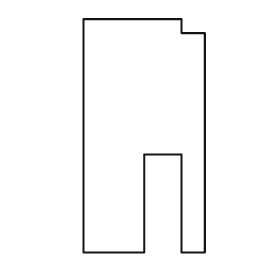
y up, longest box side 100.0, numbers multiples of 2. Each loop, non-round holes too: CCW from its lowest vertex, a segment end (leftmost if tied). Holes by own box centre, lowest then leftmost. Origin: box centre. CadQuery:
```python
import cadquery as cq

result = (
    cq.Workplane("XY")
    .moveTo(-26.0, -50.0)
    .lineTo(0.0, -50.0)
    .lineTo(0.0, -8.0)
    .lineTo(16.0, -8.0)
    .lineTo(16.0, -50.0)
    .lineTo(26.0, -50.0)
    .lineTo(26.0, 44.0)
    .lineTo(16.0, 44.0)
    .lineTo(16.0, 50.0)
    .lineTo(-26.0, 50.0)
    .close()
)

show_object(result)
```